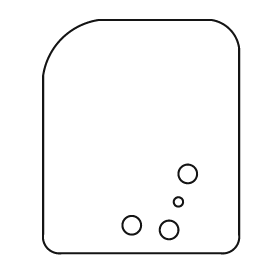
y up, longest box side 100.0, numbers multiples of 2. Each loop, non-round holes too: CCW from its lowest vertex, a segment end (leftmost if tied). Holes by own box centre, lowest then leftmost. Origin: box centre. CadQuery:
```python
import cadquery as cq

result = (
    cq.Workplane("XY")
    .moveTo(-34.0, -50.0)
    .lineTo(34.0, -50.0)
    .threePointArc((40.0, -48.0), (42.0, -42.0))
    .lineTo(42.0, 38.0)
    .threePointArc((38.0, 46.0), (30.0, 50.0))
    .lineTo(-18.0, 50.0)
    .threePointArc((-34.0, 42.0), (-42.0, 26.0))
    .lineTo(-42.0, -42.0)
    .threePointArc((-40.0, -48.0), (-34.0, -50.0))
    .close()
    .moveTo(12.0, -40.0)
    .circle(4.0)
    .moveTo(-4.0, -38.0)
    .circle(4.0)
    .moveTo(16.0, -28.0)
    .circle(2.0)
    .moveTo(20.0, -16.0)
    .circle(4.0)
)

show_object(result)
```